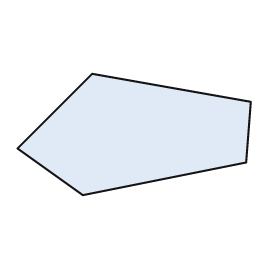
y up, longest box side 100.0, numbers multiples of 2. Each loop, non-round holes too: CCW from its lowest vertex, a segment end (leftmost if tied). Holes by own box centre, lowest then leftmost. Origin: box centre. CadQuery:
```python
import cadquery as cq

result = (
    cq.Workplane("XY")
    .moveTo(-22.0, -26.0)
    .lineTo(48.0, -12.0)
    .lineTo(50.0, 14.0)
    .lineTo(-18.0, 26.0)
    .lineTo(-50.0, -6.0)
    .close()
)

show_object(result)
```